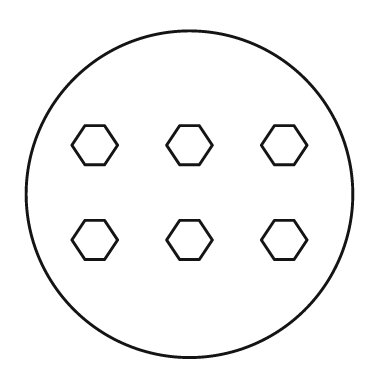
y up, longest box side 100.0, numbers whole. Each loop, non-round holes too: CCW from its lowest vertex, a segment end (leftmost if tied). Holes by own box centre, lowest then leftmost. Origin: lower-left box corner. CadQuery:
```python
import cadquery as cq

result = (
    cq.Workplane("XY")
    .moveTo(50.0, 50.0)
    .circle(50.0)
    .moveTo(18.0, 30.0)
    .lineTo(24.0, 30.0)
    .lineTo(28.0, 36.0)
    .lineTo(24.0, 42.0)
    .lineTo(18.0, 42.0)
    .lineTo(14.0, 36.0)
    .close()
    .moveTo(47.0, 30.0)
    .lineTo(53.0, 30.0)
    .lineTo(57.0, 36.0)
    .lineTo(53.0, 42.0)
    .lineTo(47.0, 42.0)
    .lineTo(43.0, 36.0)
    .close()
    .moveTo(76.0, 30.0)
    .lineTo(82.0, 30.0)
    .lineTo(86.0, 36.0)
    .lineTo(82.0, 42.0)
    .lineTo(76.0, 42.0)
    .lineTo(72.0, 36.0)
    .close()
    .moveTo(18.0, 59.0)
    .lineTo(24.0, 59.0)
    .lineTo(28.0, 65.0)
    .lineTo(24.0, 71.0)
    .lineTo(18.0, 71.0)
    .lineTo(14.0, 65.0)
    .close()
    .moveTo(47.0, 59.0)
    .lineTo(53.0, 59.0)
    .lineTo(57.0, 65.0)
    .lineTo(53.0, 71.0)
    .lineTo(47.0, 71.0)
    .lineTo(43.0, 65.0)
    .close()
    .moveTo(76.0, 59.0)
    .lineTo(82.0, 59.0)
    .lineTo(86.0, 65.0)
    .lineTo(82.0, 71.0)
    .lineTo(76.0, 71.0)
    .lineTo(72.0, 65.0)
    .close()
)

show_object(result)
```